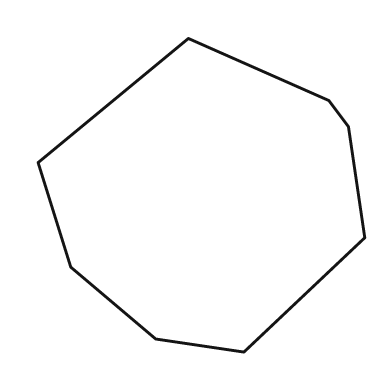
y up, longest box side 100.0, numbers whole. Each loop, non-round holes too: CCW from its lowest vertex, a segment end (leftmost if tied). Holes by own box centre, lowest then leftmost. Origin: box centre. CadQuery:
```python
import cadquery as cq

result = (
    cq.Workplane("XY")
    .moveTo(13.0, -48.0)
    .lineTo(50.0, -13.0)
    .lineTo(45.0, 21.0)
    .lineTo(39.0, 29.0)
    .lineTo(-4.0, 48.0)
    .lineTo(-50.0, 10.0)
    .lineTo(-40.0, -22.0)
    .lineTo(-14.0, -44.0)
    .close()
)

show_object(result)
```